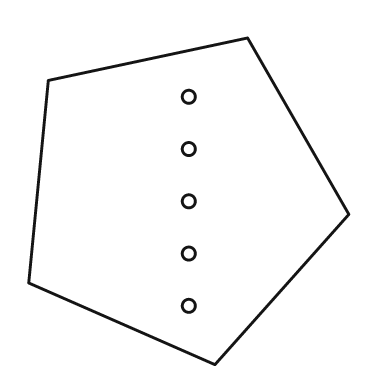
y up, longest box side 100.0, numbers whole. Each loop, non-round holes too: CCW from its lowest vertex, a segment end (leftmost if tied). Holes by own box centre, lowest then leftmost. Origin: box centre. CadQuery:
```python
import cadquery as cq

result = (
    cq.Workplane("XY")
    .moveTo(8.0, -50.0)
    .lineTo(49.0, -4.0)
    .lineTo(18.0, 50.0)
    .lineTo(-43.0, 37.0)
    .lineTo(-49.0, -25.0)
    .close()
    .moveTo(0.0, -32.0)
    .circle(2.0)
    .moveTo(0.0, -16.0)
    .circle(2.0)
    .moveTo(0.0, 0.0)
    .circle(2.0)
    .moveTo(0.0, 16.0)
    .circle(2.0)
    .moveTo(0.0, 32.0)
    .circle(2.0)
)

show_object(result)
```